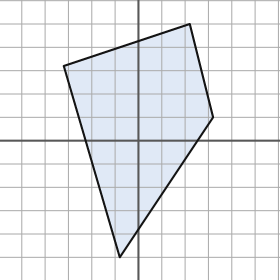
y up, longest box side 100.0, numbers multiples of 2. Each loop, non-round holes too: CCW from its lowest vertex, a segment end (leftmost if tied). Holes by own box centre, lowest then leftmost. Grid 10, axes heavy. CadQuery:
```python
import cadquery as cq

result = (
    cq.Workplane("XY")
    .moveTo(-8.0, -50.0)
    .lineTo(32.0, 10.0)
    .lineTo(22.0, 50.0)
    .lineTo(-32.0, 32.0)
    .close()
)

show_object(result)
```